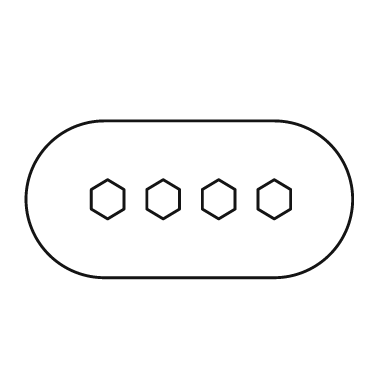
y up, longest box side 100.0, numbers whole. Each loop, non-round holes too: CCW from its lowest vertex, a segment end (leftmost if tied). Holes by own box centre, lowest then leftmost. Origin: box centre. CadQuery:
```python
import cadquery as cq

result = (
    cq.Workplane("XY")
    .moveTo(-26.0, -24.0)
    .lineTo(26.0, -24.0)
    .threePointArc((50.0, 0.0), (26.0, 24.0))
    .lineTo(-26.0, 24.0)
    .threePointArc((-50.0, 0.0), (-26.0, -24.0))
    .close()
    .moveTo(-25.0, -6.0)
    .lineTo(-20.0, -3.0)
    .lineTo(-20.0, 3.0)
    .lineTo(-25.0, 6.0)
    .lineTo(-30.0, 3.0)
    .lineTo(-30.0, -3.0)
    .close()
    .moveTo(-8.0, -6.0)
    .lineTo(-3.0, -3.0)
    .lineTo(-3.0, 3.0)
    .lineTo(-8.0, 6.0)
    .lineTo(-13.0, 3.0)
    .lineTo(-13.0, -3.0)
    .close()
    .moveTo(9.0, -6.0)
    .lineTo(14.0, -3.0)
    .lineTo(14.0, 3.0)
    .lineTo(9.0, 6.0)
    .lineTo(4.0, 3.0)
    .lineTo(4.0, -3.0)
    .close()
    .moveTo(26.0, -6.0)
    .lineTo(31.0, -3.0)
    .lineTo(31.0, 3.0)
    .lineTo(26.0, 6.0)
    .lineTo(21.0, 3.0)
    .lineTo(21.0, -3.0)
    .close()
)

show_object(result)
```